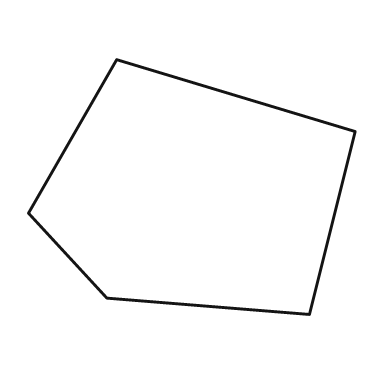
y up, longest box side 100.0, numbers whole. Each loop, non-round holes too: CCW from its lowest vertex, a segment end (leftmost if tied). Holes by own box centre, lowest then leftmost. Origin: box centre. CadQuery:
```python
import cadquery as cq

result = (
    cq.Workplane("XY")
    .moveTo(36.0, -39.0)
    .lineTo(50.0, 17.0)
    .lineTo(-23.0, 39.0)
    .lineTo(-50.0, -8.0)
    .lineTo(-26.0, -34.0)
    .close()
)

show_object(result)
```